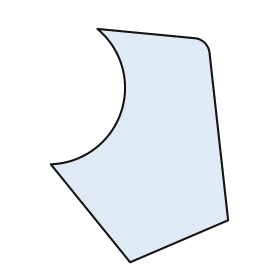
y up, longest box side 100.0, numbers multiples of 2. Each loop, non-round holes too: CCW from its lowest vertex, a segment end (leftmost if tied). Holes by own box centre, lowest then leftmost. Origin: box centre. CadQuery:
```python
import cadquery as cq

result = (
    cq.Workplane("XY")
    .moveTo(-4.0, -50.0)
    .lineTo(38.0, -32.0)
    .lineTo(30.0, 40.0)
    .threePointArc((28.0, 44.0), (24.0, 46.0))
    .lineTo(-18.0, 50.0)
    .threePointArc((-8.0, 14.0), (-38.0, -8.0))
    .close()
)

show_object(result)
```